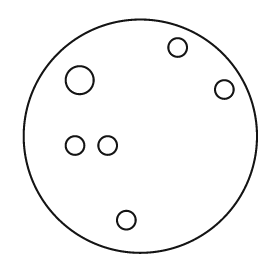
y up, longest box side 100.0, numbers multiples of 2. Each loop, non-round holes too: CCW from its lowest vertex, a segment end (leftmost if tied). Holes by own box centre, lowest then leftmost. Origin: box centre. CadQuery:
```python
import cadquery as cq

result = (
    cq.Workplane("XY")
    .moveTo(0.0, 0.0)
    .circle(50.0)
    .moveTo(-6.0, -36.0)
    .circle(4.0)
    .moveTo(-28.0, -4.0)
    .circle(4.0)
    .moveTo(-14.0, -4.0)
    .circle(4.0)
    .moveTo(36.0, 20.0)
    .circle(4.0)
    .moveTo(-26.0, 24.0)
    .circle(6.0)
    .moveTo(16.0, 38.0)
    .circle(4.0)
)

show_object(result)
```